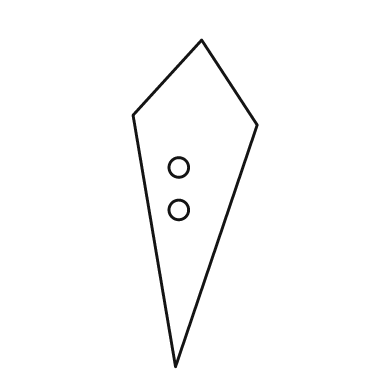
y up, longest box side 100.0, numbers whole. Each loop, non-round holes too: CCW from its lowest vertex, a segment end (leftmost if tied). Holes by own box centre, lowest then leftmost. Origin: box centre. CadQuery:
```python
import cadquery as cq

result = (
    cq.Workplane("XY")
    .moveTo(-6.0, -50.0)
    .lineTo(19.0, 24.0)
    .lineTo(2.0, 50.0)
    .lineTo(-19.0, 27.0)
    .close()
    .moveTo(-5.0, -2.0)
    .circle(3.0)
    .moveTo(-5.0, 11.0)
    .circle(3.0)
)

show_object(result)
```